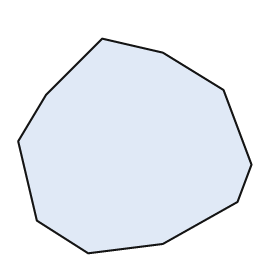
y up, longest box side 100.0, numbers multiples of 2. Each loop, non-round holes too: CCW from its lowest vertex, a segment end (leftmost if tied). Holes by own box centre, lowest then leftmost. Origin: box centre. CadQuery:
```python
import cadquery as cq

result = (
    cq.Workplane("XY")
    .moveTo(-20.0, -46.0)
    .lineTo(12.0, -42.0)
    .lineTo(44.0, -24.0)
    .lineTo(50.0, -8.0)
    .lineTo(38.0, 24.0)
    .lineTo(12.0, 40.0)
    .lineTo(-14.0, 46.0)
    .lineTo(-38.0, 22.0)
    .lineTo(-50.0, 2.0)
    .lineTo(-42.0, -32.0)
    .close()
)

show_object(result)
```